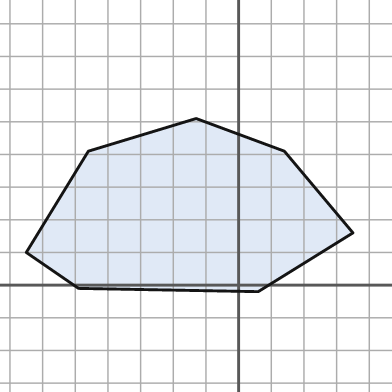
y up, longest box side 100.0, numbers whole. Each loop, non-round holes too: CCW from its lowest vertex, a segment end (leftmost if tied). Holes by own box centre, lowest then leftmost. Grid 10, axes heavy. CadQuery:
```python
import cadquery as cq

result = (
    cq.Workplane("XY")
    .moveTo(6.0, -2.0)
    .lineTo(35.0, 16.0)
    .lineTo(14.0, 41.0)
    .lineTo(-13.0, 51.0)
    .lineTo(-46.0, 41.0)
    .lineTo(-65.0, 10.0)
    .lineTo(-49.0, -1.0)
    .close()
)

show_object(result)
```